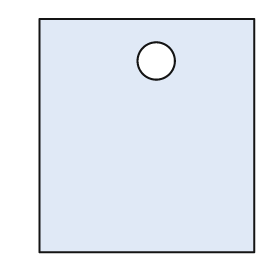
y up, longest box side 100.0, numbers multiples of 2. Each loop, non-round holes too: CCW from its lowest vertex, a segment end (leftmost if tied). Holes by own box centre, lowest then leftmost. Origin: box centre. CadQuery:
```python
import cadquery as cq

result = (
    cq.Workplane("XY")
    .moveTo(-46.0, -50.0)
    .lineTo(46.0, -50.0)
    .lineTo(46.0, 50.0)
    .lineTo(-46.0, 50.0)
    .close()
    .moveTo(4.0, 32.0)
    .circle(8.0)
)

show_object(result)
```